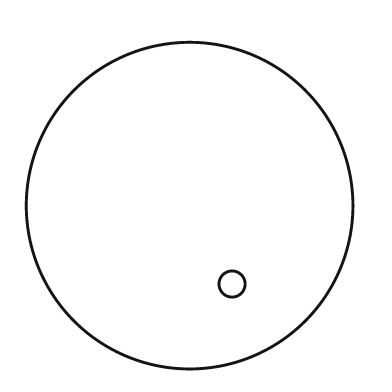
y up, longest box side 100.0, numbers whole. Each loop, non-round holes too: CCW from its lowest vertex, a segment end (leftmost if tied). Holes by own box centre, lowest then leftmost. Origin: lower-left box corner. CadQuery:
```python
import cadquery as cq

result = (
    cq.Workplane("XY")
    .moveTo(50.0, 50.0)
    .circle(50.0)
    .moveTo(63.0, 26.0)
    .circle(4.0)
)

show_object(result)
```